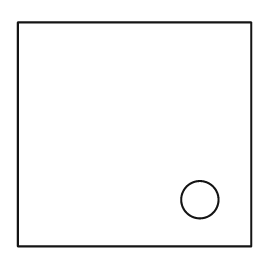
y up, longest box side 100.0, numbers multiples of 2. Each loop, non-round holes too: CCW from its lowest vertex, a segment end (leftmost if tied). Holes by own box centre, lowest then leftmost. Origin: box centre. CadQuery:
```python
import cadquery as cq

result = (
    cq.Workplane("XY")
    .moveTo(-50.0, -48.0)
    .lineTo(50.0, -48.0)
    .lineTo(50.0, 48.0)
    .lineTo(-50.0, 48.0)
    .close()
    .moveTo(28.0, -28.0)
    .circle(8.0)
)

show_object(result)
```